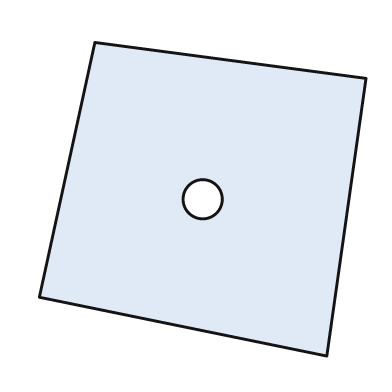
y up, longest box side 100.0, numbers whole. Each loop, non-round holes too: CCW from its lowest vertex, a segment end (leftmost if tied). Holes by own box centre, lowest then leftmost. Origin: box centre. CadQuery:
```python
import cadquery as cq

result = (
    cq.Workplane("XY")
    .moveTo(38.0, -48.0)
    .lineTo(50.0, 37.0)
    .lineTo(-33.0, 48.0)
    .lineTo(-50.0, -30.0)
    .close()
    .moveTo(0.0, 0.0)
    .circle(6.0)
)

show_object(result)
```